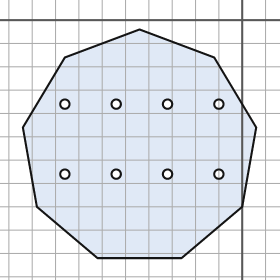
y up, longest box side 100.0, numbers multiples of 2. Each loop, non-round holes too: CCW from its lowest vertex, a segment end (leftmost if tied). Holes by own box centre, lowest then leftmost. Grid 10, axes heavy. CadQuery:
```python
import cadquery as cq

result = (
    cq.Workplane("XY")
    .moveTo(-62.0, -102.0)
    .lineTo(-26.0, -102.0)
    .lineTo(0.0, -80.0)
    .lineTo(6.0, -46.0)
    .lineTo(-12.0, -16.0)
    .lineTo(-44.0, -4.0)
    .lineTo(-76.0, -16.0)
    .lineTo(-94.0, -46.0)
    .lineTo(-88.0, -80.0)
    .close()
    .moveTo(-76.0, -66.0)
    .circle(2.0)
    .moveTo(-54.0, -66.0)
    .circle(2.0)
    .moveTo(-32.0, -66.0)
    .circle(2.0)
    .moveTo(-10.0, -66.0)
    .circle(2.0)
    .moveTo(-76.0, -36.0)
    .circle(2.0)
    .moveTo(-54.0, -36.0)
    .circle(2.0)
    .moveTo(-32.0, -36.0)
    .circle(2.0)
    .moveTo(-10.0, -36.0)
    .circle(2.0)
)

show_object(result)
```